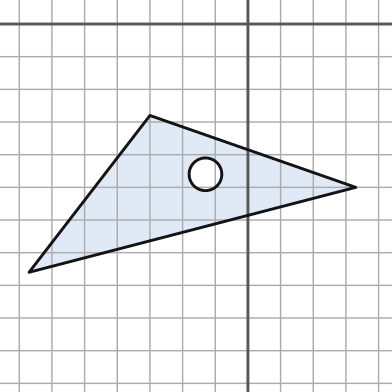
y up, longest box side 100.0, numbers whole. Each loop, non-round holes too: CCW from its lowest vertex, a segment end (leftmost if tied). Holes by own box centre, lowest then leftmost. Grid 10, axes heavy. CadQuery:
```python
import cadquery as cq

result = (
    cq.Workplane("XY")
    .moveTo(-67.0, -76.0)
    .lineTo(33.0, -50.0)
    .lineTo(-30.0, -28.0)
    .close()
    .moveTo(-13.0, -46.0)
    .circle(5.0)
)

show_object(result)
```